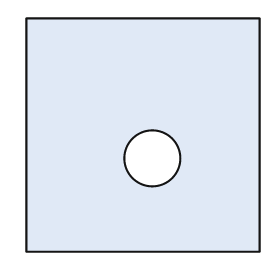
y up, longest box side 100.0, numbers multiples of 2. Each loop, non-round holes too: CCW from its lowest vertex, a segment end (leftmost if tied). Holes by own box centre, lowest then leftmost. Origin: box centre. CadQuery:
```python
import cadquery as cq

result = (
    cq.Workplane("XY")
    .moveTo(-50.0, -50.0)
    .lineTo(50.0, -50.0)
    .lineTo(50.0, 50.0)
    .lineTo(-50.0, 50.0)
    .close()
    .moveTo(4.0, -10.0)
    .circle(12.0)
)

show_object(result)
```